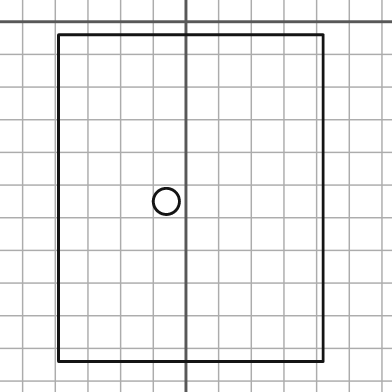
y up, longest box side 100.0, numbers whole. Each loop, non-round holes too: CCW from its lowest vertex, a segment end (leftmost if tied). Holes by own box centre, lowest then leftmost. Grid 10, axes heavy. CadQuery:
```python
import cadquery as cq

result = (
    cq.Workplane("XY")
    .moveTo(-39.0, -104.0)
    .lineTo(42.0, -104.0)
    .lineTo(42.0, -4.0)
    .lineTo(-39.0, -4.0)
    .close()
    .moveTo(-6.0, -55.0)
    .circle(4.0)
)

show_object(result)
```